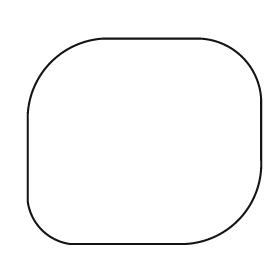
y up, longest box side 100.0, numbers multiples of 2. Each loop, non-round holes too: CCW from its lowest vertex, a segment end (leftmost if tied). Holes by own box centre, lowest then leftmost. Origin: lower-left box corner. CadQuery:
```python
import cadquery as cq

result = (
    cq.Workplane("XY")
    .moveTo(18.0, 0.0)
    .lineTo(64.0, 0.0)
    .threePointArc((90.0, 10.0), (100.0, 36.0))
    .lineTo(100.0, 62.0)
    .threePointArc((92.0, 80.0), (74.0, 88.0))
    .lineTo(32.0, 88.0)
    .threePointArc((10.0, 78.0), (0.0, 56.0))
    .lineTo(0.0, 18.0)
    .threePointArc((6.0, 6.0), (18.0, 0.0))
    .close()
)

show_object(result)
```